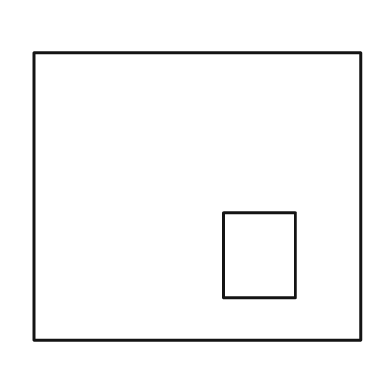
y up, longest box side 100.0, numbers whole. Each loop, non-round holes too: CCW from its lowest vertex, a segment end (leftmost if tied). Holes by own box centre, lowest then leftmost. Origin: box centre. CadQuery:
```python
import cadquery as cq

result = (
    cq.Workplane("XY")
    .moveTo(-50.0, -44.0)
    .lineTo(50.0, -44.0)
    .lineTo(50.0, 44.0)
    .lineTo(-50.0, 44.0)
    .close()
    .moveTo(8.0, -31.0)
    .lineTo(30.0, -31.0)
    .lineTo(30.0, -5.0)
    .lineTo(8.0, -5.0)
    .close()
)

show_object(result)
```